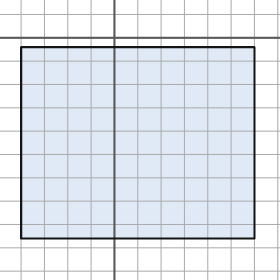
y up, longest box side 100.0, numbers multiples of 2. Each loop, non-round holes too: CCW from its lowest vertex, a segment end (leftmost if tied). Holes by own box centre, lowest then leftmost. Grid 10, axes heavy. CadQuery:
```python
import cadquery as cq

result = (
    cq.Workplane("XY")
    .moveTo(-40.0, -86.0)
    .lineTo(60.0, -86.0)
    .lineTo(60.0, -4.0)
    .lineTo(-40.0, -4.0)
    .close()
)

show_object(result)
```